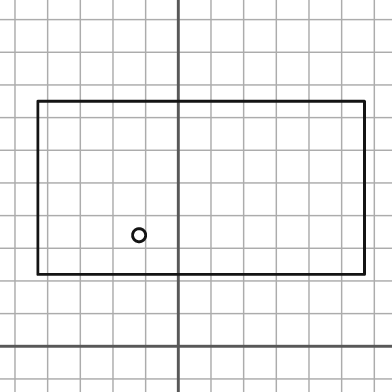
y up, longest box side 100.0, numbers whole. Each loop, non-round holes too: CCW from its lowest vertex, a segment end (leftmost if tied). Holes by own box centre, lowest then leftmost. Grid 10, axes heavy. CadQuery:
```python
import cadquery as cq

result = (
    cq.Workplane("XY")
    .moveTo(-43.0, 22.0)
    .lineTo(57.0, 22.0)
    .lineTo(57.0, 75.0)
    .lineTo(-43.0, 75.0)
    .close()
    .moveTo(-12.0, 34.0)
    .circle(2.0)
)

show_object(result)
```